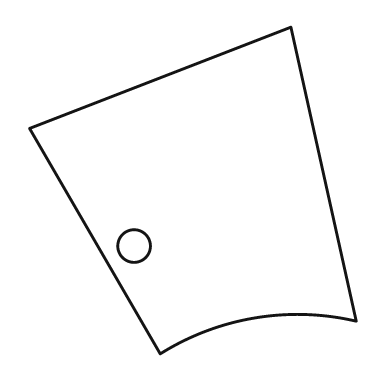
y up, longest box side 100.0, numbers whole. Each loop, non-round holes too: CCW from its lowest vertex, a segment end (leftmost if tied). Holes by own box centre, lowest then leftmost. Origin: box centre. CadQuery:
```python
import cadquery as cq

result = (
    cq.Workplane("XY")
    .moveTo(-10.0, -50.0)
    .threePointArc((19.0, -39.0), (50.0, -40.0))
    .lineTo(30.0, 50.0)
    .lineTo(-50.0, 19.0)
    .close()
    .moveTo(-18.0, -17.0)
    .circle(5.0)
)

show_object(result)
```